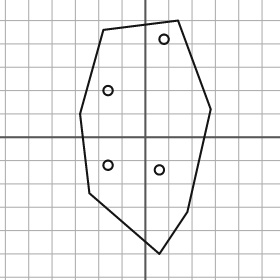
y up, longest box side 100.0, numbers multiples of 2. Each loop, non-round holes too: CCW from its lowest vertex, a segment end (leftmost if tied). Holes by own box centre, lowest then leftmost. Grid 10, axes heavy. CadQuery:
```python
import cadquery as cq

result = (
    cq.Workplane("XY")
    .moveTo(6.0, -50.0)
    .lineTo(18.0, -32.0)
    .lineTo(28.0, 12.0)
    .lineTo(14.0, 50.0)
    .lineTo(-18.0, 46.0)
    .lineTo(-28.0, 10.0)
    .lineTo(-24.0, -24.0)
    .close()
    .moveTo(6.0, -14.0)
    .circle(2.0)
    .moveTo(-16.0, -12.0)
    .circle(2.0)
    .moveTo(-16.0, 20.0)
    .circle(2.0)
    .moveTo(8.0, 42.0)
    .circle(2.0)
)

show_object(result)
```